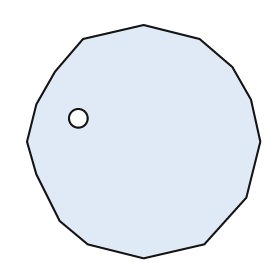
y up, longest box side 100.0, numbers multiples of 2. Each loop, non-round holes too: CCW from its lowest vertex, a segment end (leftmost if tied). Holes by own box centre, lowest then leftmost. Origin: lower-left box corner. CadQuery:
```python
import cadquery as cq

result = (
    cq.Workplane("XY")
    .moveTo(50.0, 0.0)
    .lineTo(76.0, 6.0)
    .lineTo(94.0, 26.0)
    .lineTo(100.0, 50.0)
    .lineTo(96.0, 68.0)
    .lineTo(88.0, 82.0)
    .lineTo(74.0, 94.0)
    .lineTo(50.0, 100.0)
    .lineTo(24.0, 94.0)
    .lineTo(12.0, 80.0)
    .lineTo(4.0, 66.0)
    .lineTo(0.0, 50.0)
    .lineTo(4.0, 36.0)
    .lineTo(14.0, 16.0)
    .lineTo(26.0, 6.0)
    .close()
    .moveTo(22.0, 60.0)
    .circle(4.0)
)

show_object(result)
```